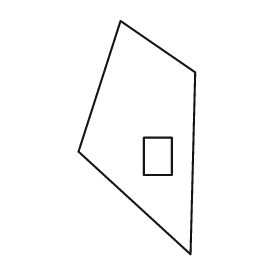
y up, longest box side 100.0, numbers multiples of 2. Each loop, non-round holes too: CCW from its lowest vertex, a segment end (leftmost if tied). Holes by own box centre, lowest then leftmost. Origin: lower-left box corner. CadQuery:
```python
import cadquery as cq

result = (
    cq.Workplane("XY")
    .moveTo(48.0, 0.0)
    .lineTo(50.0, 78.0)
    .lineTo(18.0, 100.0)
    .lineTo(0.0, 44.0)
    .close()
    .moveTo(28.0, 34.0)
    .lineTo(40.0, 34.0)
    .lineTo(40.0, 50.0)
    .lineTo(28.0, 50.0)
    .close()
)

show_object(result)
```